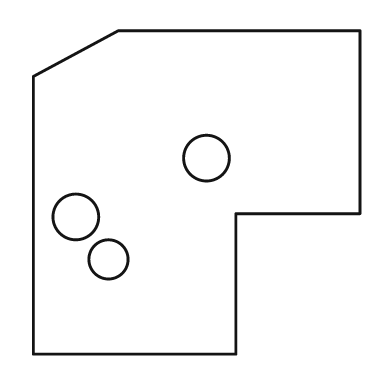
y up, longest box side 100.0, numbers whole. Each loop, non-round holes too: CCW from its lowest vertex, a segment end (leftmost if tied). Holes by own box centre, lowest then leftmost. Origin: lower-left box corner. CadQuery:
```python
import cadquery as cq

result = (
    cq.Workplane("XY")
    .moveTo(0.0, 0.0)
    .lineTo(62.0, 0.0)
    .lineTo(62.0, 43.0)
    .lineTo(100.0, 43.0)
    .lineTo(100.0, 99.0)
    .lineTo(26.0, 99.0)
    .lineTo(0.0, 85.0)
    .close()
    .moveTo(23.0, 29.0)
    .circle(6.0)
    .moveTo(13.0, 42.0)
    .circle(7.0)
    .moveTo(53.0, 60.0)
    .circle(7.0)
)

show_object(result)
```